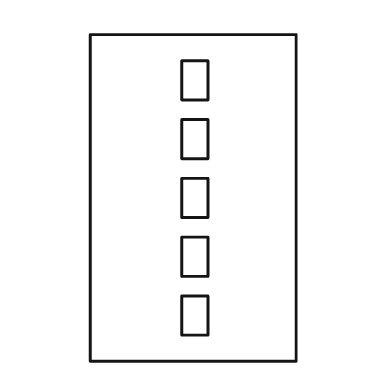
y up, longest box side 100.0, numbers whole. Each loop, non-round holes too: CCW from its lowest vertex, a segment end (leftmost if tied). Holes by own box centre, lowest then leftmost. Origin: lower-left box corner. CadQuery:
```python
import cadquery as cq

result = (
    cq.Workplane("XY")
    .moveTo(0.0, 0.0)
    .lineTo(63.0, 0.0)
    .lineTo(63.0, 100.0)
    .lineTo(0.0, 100.0)
    .close()
    .moveTo(28.0, 8.0)
    .lineTo(36.0, 8.0)
    .lineTo(36.0, 20.0)
    .lineTo(28.0, 20.0)
    .close()
    .moveTo(28.0, 26.0)
    .lineTo(36.0, 26.0)
    .lineTo(36.0, 38.0)
    .lineTo(28.0, 38.0)
    .close()
    .moveTo(28.0, 44.0)
    .lineTo(36.0, 44.0)
    .lineTo(36.0, 56.0)
    .lineTo(28.0, 56.0)
    .close()
    .moveTo(28.0, 62.0)
    .lineTo(36.0, 62.0)
    .lineTo(36.0, 74.0)
    .lineTo(28.0, 74.0)
    .close()
    .moveTo(28.0, 80.0)
    .lineTo(36.0, 80.0)
    .lineTo(36.0, 92.0)
    .lineTo(28.0, 92.0)
    .close()
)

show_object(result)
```